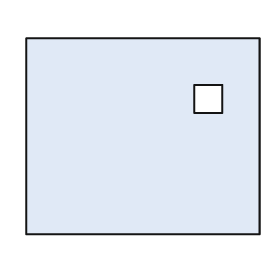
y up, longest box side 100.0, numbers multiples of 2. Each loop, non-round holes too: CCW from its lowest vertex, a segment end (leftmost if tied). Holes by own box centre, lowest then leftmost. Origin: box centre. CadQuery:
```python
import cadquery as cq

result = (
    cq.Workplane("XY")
    .moveTo(-50.0, -42.0)
    .lineTo(50.0, -42.0)
    .lineTo(50.0, 42.0)
    .lineTo(-50.0, 42.0)
    .close()
    .moveTo(22.0, 10.0)
    .lineTo(34.0, 10.0)
    .lineTo(34.0, 22.0)
    .lineTo(22.0, 22.0)
    .close()
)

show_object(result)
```